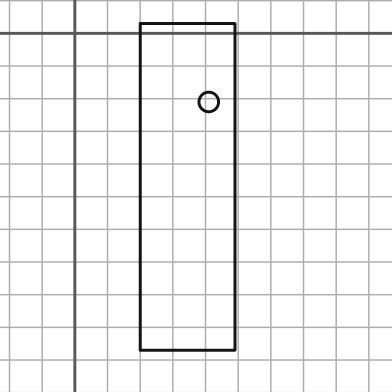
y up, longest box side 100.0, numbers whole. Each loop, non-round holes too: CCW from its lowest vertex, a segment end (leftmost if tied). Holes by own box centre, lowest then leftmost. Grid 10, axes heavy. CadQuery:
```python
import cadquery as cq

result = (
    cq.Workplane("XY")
    .moveTo(20.0, -97.0)
    .lineTo(49.0, -97.0)
    .lineTo(49.0, 3.0)
    .lineTo(20.0, 3.0)
    .close()
    .moveTo(41.0, -21.0)
    .circle(3.0)
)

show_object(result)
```